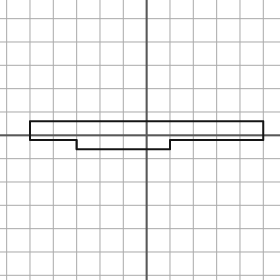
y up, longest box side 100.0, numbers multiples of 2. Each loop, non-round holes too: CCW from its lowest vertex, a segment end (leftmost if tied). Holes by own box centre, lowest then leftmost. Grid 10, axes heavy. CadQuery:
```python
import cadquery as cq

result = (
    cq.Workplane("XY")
    .moveTo(-30.0, -6.0)
    .lineTo(10.0, -6.0)
    .lineTo(10.0, -2.0)
    .lineTo(50.0, -2.0)
    .lineTo(50.0, 6.0)
    .lineTo(-50.0, 6.0)
    .lineTo(-50.0, -2.0)
    .lineTo(-30.0, -2.0)
    .close()
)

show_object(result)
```